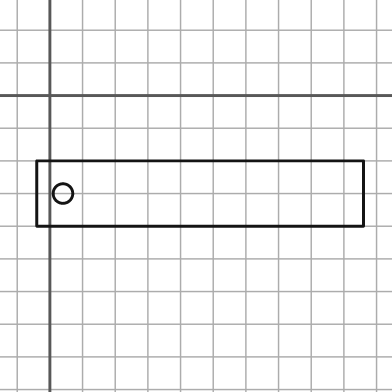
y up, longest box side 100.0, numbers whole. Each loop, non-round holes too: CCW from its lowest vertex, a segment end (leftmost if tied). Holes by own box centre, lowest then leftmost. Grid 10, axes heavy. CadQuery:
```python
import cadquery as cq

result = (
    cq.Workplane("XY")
    .moveTo(-4.0, -40.0)
    .lineTo(96.0, -40.0)
    .lineTo(96.0, -20.0)
    .lineTo(-4.0, -20.0)
    .close()
    .moveTo(4.0, -30.0)
    .circle(3.0)
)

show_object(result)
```